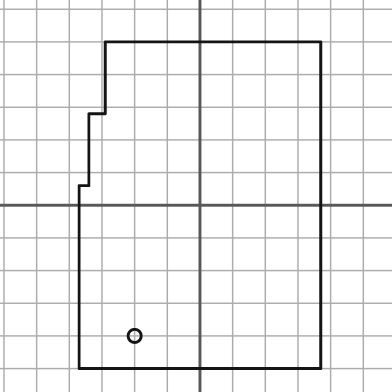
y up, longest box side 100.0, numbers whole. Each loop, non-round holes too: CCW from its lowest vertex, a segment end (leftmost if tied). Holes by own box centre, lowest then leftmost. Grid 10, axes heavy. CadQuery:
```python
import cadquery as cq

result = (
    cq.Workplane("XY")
    .moveTo(-37.0, -50.0)
    .lineTo(37.0, -50.0)
    .lineTo(37.0, 50.0)
    .lineTo(-29.0, 50.0)
    .lineTo(-29.0, 28.0)
    .lineTo(-34.0, 28.0)
    .lineTo(-34.0, 6.0)
    .lineTo(-37.0, 6.0)
    .close()
    .moveTo(-20.0, -40.0)
    .circle(2.0)
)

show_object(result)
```